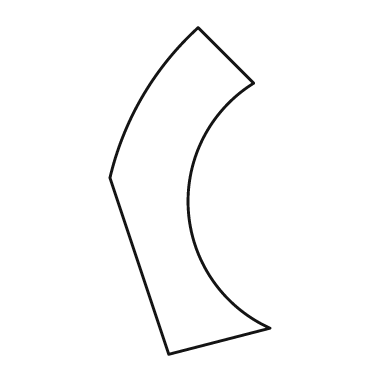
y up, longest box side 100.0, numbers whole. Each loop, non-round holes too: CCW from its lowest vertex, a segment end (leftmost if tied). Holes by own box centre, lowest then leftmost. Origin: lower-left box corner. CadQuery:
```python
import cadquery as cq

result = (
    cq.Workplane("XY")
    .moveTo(18.0, 0.0)
    .lineTo(49.0, 8.0)
    .threePointArc((24.0, 44.0), (44.0, 83.0))
    .lineTo(27.0, 100.0)
    .threePointArc((10.0, 79.0), (0.0, 54.0))
    .close()
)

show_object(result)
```